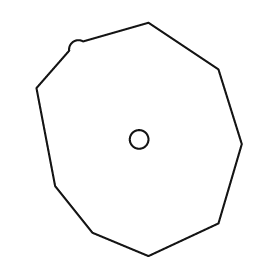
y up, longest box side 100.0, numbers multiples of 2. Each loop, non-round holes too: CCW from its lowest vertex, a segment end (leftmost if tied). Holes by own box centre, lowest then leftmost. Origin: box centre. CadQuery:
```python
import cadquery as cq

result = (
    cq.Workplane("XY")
    .moveTo(4.0, -50.0)
    .lineTo(34.0, -36.0)
    .lineTo(44.0, -2.0)
    .lineTo(34.0, 30.0)
    .lineTo(4.0, 50.0)
    .lineTo(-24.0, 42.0)
    .threePointArc((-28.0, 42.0), (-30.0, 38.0))
    .lineTo(-44.0, 22.0)
    .lineTo(-36.0, -20.0)
    .lineTo(-20.0, -40.0)
    .close()
    .moveTo(0.0, 0.0)
    .circle(4.0)
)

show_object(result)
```